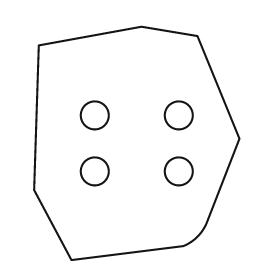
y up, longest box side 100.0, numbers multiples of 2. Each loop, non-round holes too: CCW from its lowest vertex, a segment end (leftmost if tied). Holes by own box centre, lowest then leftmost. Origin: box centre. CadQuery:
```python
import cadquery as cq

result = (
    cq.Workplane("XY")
    .moveTo(-28.0, -50.0)
    .lineTo(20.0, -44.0)
    .threePointArc((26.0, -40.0), (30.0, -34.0))
    .lineTo(44.0, 2.0)
    .lineTo(26.0, 46.0)
    .lineTo(2.0, 50.0)
    .lineTo(-42.0, 42.0)
    .lineTo(-44.0, -20.0)
    .close()
    .moveTo(-18.0, -12.0)
    .circle(6.0)
    .moveTo(18.0, -12.0)
    .circle(6.0)
    .moveTo(-18.0, 12.0)
    .circle(6.0)
    .moveTo(18.0, 12.0)
    .circle(6.0)
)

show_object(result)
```